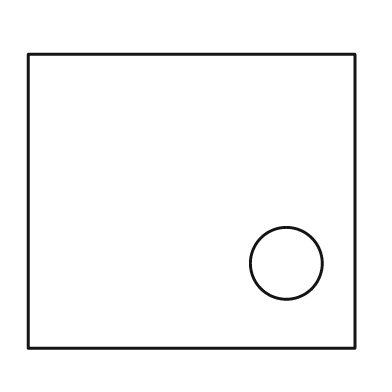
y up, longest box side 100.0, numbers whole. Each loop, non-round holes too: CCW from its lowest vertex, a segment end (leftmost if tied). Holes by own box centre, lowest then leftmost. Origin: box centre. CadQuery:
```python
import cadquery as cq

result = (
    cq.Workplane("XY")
    .moveTo(-50.0, -45.0)
    .lineTo(50.0, -45.0)
    .lineTo(50.0, 45.0)
    .lineTo(-50.0, 45.0)
    .close()
    .moveTo(29.0, -19.0)
    .circle(11.0)
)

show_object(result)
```